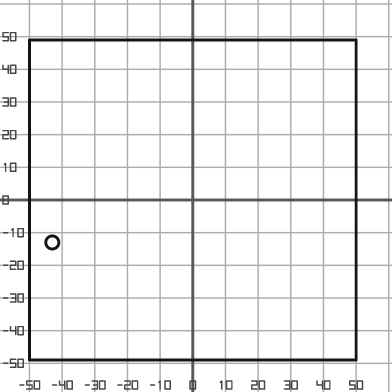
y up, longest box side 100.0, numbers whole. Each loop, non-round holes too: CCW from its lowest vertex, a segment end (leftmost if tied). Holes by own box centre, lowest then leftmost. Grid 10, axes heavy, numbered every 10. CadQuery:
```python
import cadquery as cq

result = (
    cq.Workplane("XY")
    .moveTo(-50.0, -49.0)
    .lineTo(50.0, -49.0)
    .lineTo(50.0, 49.0)
    .lineTo(-50.0, 49.0)
    .close()
    .moveTo(-43.0, -13.0)
    .circle(2.0)
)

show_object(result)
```